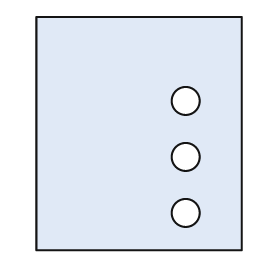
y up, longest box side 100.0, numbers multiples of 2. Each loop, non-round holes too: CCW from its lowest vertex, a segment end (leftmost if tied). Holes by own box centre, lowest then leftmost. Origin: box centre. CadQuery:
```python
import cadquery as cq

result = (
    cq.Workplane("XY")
    .moveTo(-44.0, -50.0)
    .lineTo(44.0, -50.0)
    .lineTo(44.0, 50.0)
    .lineTo(-44.0, 50.0)
    .close()
    .moveTo(20.0, -34.0)
    .circle(6.0)
    .moveTo(20.0, -10.0)
    .circle(6.0)
    .moveTo(20.0, 14.0)
    .circle(6.0)
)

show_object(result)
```